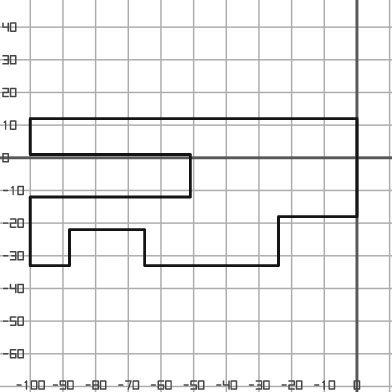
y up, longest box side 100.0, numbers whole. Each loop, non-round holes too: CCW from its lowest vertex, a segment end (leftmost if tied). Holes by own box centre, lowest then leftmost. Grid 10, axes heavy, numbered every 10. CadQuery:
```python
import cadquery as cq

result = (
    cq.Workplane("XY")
    .moveTo(-100.0, -33.0)
    .lineTo(-88.0, -33.0)
    .lineTo(-88.0, -22.0)
    .lineTo(-65.0, -22.0)
    .lineTo(-65.0, -33.0)
    .lineTo(-24.0, -33.0)
    .lineTo(-24.0, -18.0)
    .lineTo(0.0, -18.0)
    .lineTo(0.0, 12.0)
    .lineTo(-100.0, 12.0)
    .lineTo(-100.0, 1.0)
    .lineTo(-51.0, 1.0)
    .lineTo(-51.0, -12.0)
    .lineTo(-100.0, -12.0)
    .close()
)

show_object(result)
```